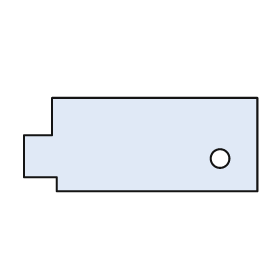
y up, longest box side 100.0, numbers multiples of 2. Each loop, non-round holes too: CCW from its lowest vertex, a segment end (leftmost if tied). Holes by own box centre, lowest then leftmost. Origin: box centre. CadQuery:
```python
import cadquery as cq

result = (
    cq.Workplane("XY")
    .moveTo(-36.0, -20.0)
    .lineTo(50.0, -20.0)
    .lineTo(50.0, 20.0)
    .lineTo(-38.0, 20.0)
    .lineTo(-38.0, 4.0)
    .lineTo(-50.0, 4.0)
    .lineTo(-50.0, -14.0)
    .lineTo(-36.0, -14.0)
    .close()
    .moveTo(34.0, -6.0)
    .circle(4.0)
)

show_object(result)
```